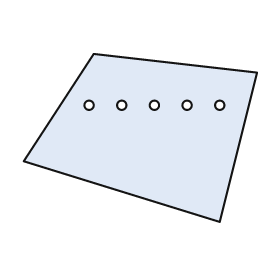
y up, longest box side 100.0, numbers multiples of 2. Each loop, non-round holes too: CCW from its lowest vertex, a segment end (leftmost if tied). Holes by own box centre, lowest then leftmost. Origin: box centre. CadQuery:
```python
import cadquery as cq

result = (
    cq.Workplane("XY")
    .moveTo(34.0, -36.0)
    .lineTo(50.0, 28.0)
    .lineTo(-20.0, 36.0)
    .lineTo(-50.0, -10.0)
    .close()
    .moveTo(-22.0, 14.0)
    .circle(2.0)
    .moveTo(-8.0, 14.0)
    .circle(2.0)
    .moveTo(6.0, 14.0)
    .circle(2.0)
    .moveTo(20.0, 14.0)
    .circle(2.0)
    .moveTo(34.0, 14.0)
    .circle(2.0)
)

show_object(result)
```